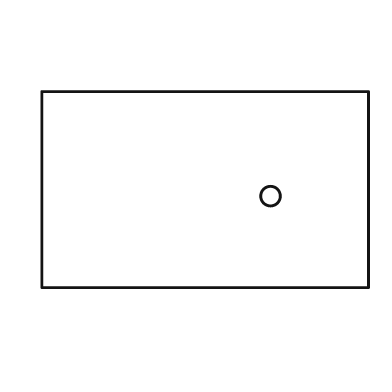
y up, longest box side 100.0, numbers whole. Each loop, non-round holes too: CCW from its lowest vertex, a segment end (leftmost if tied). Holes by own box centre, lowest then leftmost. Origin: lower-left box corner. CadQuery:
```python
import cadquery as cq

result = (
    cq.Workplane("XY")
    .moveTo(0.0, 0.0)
    .lineTo(100.0, 0.0)
    .lineTo(100.0, 60.0)
    .lineTo(0.0, 60.0)
    .close()
    .moveTo(70.0, 28.0)
    .circle(3.0)
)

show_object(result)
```